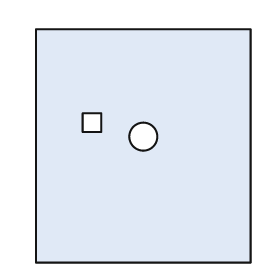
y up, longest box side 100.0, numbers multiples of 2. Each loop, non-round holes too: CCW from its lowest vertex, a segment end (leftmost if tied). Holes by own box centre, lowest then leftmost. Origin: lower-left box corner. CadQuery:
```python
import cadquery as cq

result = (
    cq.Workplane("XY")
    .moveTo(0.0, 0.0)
    .lineTo(92.0, 0.0)
    .lineTo(92.0, 100.0)
    .lineTo(0.0, 100.0)
    .close()
    .moveTo(46.0, 54.0)
    .circle(6.0)
    .moveTo(20.0, 56.0)
    .lineTo(28.0, 56.0)
    .lineTo(28.0, 64.0)
    .lineTo(20.0, 64.0)
    .close()
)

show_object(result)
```